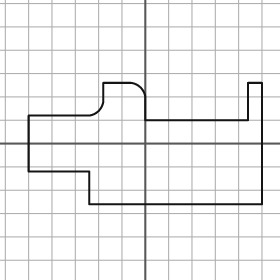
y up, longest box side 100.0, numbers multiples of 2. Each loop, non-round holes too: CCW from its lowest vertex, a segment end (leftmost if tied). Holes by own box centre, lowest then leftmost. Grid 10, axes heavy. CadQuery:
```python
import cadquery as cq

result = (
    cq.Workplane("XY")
    .moveTo(-24.0, -26.0)
    .lineTo(50.0, -26.0)
    .lineTo(50.0, 26.0)
    .lineTo(44.0, 26.0)
    .lineTo(44.0, 10.0)
    .lineTo(0.0, 10.0)
    .lineTo(0.0, 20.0)
    .threePointArc((-2.0, 24.0), (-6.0, 26.0))
    .lineTo(-18.0, 26.0)
    .lineTo(-18.0, 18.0)
    .threePointArc((-20.0, 14.0), (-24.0, 12.0))
    .lineTo(-50.0, 12.0)
    .lineTo(-50.0, -12.0)
    .lineTo(-24.0, -12.0)
    .close()
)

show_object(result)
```